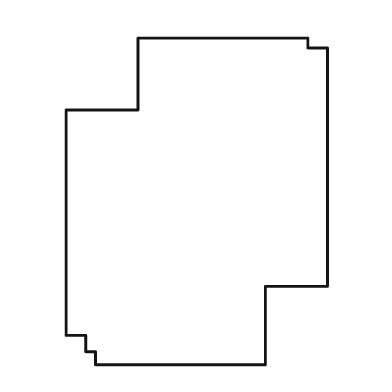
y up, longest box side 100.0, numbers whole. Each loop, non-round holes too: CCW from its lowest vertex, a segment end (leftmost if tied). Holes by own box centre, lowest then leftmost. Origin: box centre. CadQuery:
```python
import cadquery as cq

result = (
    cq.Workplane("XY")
    .moveTo(-31.0, -50.0)
    .lineTo(21.0, -50.0)
    .lineTo(21.0, -26.0)
    .lineTo(40.0, -26.0)
    .lineTo(40.0, 47.0)
    .lineTo(34.0, 47.0)
    .lineTo(34.0, 50.0)
    .lineTo(-18.0, 50.0)
    .lineTo(-18.0, 28.0)
    .lineTo(-40.0, 28.0)
    .lineTo(-40.0, -41.0)
    .lineTo(-34.0, -41.0)
    .lineTo(-34.0, -46.0)
    .lineTo(-31.0, -46.0)
    .close()
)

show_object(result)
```